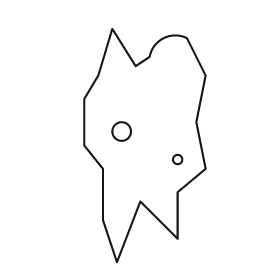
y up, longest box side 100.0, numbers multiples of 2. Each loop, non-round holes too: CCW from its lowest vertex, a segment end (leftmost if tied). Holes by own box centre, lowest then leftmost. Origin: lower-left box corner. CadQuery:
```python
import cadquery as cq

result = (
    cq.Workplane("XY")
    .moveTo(14.0, 0.0)
    .lineTo(24.0, 26.0)
    .lineTo(40.0, 10.0)
    .lineTo(40.0, 30.0)
    .lineTo(52.0, 40.0)
    .lineTo(48.0, 60.0)
    .lineTo(52.0, 80.0)
    .lineTo(44.0, 96.0)
    .threePointArc((34.0, 96.0), (28.0, 88.0))
    .lineTo(22.0, 84.0)
    .lineTo(12.0, 100.0)
    .lineTo(6.0, 80.0)
    .lineTo(0.0, 70.0)
    .lineTo(0.0, 50.0)
    .lineTo(8.0, 40.0)
    .lineTo(8.0, 18.0)
    .close()
    .moveTo(40.0, 44.0)
    .circle(2.0)
    .moveTo(16.0, 56.0)
    .circle(4.0)
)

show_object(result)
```